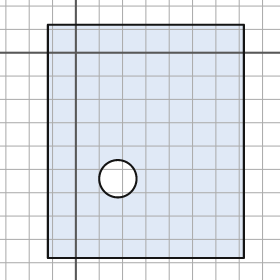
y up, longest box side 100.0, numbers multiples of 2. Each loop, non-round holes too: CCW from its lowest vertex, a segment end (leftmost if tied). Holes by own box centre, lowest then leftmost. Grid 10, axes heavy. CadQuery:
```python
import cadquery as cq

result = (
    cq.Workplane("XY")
    .moveTo(-12.0, -88.0)
    .lineTo(72.0, -88.0)
    .lineTo(72.0, 12.0)
    .lineTo(-12.0, 12.0)
    .close()
    .moveTo(18.0, -54.0)
    .circle(8.0)
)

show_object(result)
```